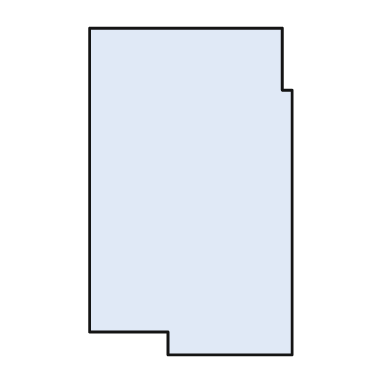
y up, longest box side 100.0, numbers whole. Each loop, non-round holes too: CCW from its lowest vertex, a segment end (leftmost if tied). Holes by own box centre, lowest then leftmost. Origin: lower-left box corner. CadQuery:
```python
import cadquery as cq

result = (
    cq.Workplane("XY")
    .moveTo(24.0, 0.0)
    .lineTo(62.0, 0.0)
    .lineTo(62.0, 81.0)
    .lineTo(59.0, 81.0)
    .lineTo(59.0, 100.0)
    .lineTo(0.0, 100.0)
    .lineTo(0.0, 7.0)
    .lineTo(24.0, 7.0)
    .close()
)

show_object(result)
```